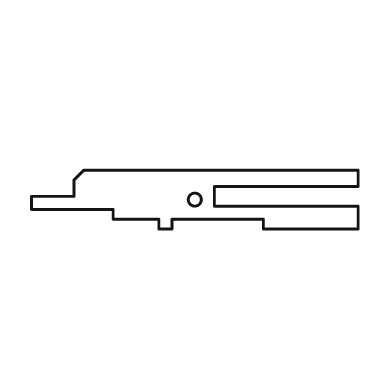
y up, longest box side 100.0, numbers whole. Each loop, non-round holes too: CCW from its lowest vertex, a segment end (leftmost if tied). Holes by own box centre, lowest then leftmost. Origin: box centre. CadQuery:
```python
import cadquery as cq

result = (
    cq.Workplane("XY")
    .moveTo(-11.0, -9.0)
    .lineTo(-7.0, -9.0)
    .lineTo(-7.0, -6.0)
    .lineTo(21.0, -6.0)
    .lineTo(21.0, -9.0)
    .lineTo(50.0, -9.0)
    .lineTo(50.0, -2.0)
    .lineTo(6.0, -2.0)
    .lineTo(6.0, 4.0)
    .lineTo(50.0, 4.0)
    .lineTo(50.0, 9.0)
    .lineTo(-34.0, 9.0)
    .lineTo(-37.0, 6.0)
    .lineTo(-37.0, 1.0)
    .lineTo(-50.0, 1.0)
    .lineTo(-50.0, -3.0)
    .lineTo(-25.0, -3.0)
    .lineTo(-25.0, -6.0)
    .lineTo(-11.0, -6.0)
    .close()
    .moveTo(0.0, 0.0)
    .circle(2.0)
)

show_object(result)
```